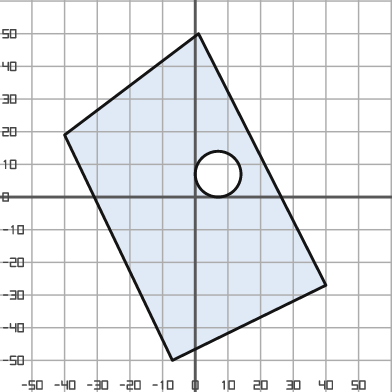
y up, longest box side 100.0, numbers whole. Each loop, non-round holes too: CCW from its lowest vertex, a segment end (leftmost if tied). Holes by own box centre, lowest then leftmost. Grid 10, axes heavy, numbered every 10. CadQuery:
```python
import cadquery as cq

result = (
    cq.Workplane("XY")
    .moveTo(-7.0, -50.0)
    .lineTo(40.0, -27.0)
    .lineTo(1.0, 50.0)
    .lineTo(-40.0, 19.0)
    .close()
    .moveTo(7.0, 7.0)
    .circle(7.0)
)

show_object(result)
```